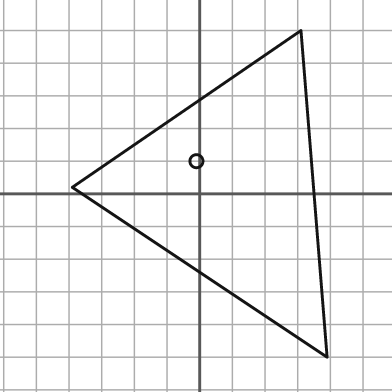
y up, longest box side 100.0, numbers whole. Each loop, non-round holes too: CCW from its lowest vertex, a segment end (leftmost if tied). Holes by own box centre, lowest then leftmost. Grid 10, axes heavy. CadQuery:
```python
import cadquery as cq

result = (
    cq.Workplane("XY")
    .moveTo(39.0, -50.0)
    .lineTo(31.0, 50.0)
    .lineTo(-39.0, 2.0)
    .close()
    .moveTo(-1.0, 10.0)
    .circle(2.0)
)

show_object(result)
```